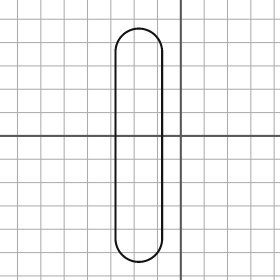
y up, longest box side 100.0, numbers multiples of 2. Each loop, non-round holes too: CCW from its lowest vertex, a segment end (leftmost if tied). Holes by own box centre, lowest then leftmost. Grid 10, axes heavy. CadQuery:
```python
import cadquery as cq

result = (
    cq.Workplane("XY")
    .moveTo(-28.0, -44.0)
    .threePointArc((-18.0, -54.0), (-8.0, -44.0))
    .lineTo(-8.0, 36.0)
    .threePointArc((-18.0, 46.0), (-28.0, 36.0))
    .close()
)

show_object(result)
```